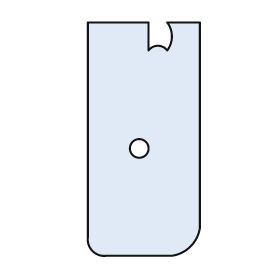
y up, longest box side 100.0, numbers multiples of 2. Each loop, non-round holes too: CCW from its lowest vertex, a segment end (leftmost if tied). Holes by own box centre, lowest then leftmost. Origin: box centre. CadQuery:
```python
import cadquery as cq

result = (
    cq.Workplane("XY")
    .moveTo(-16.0, -50.0)
    .lineTo(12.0, -50.0)
    .threePointArc((20.0, -46.0), (24.0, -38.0))
    .lineTo(24.0, 50.0)
    .lineTo(10.0, 50.0)
    .threePointArc((12.0, 44.0), (10.0, 38.0))
    .threePointArc((6.0, 40.0), (2.0, 38.0))
    .lineTo(2.0, 50.0)
    .lineTo(-24.0, 50.0)
    .lineTo(-24.0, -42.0)
    .threePointArc((-22.0, -48.0), (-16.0, -50.0))
    .close()
    .moveTo(-2.0, -4.0)
    .circle(4.0)
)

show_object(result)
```